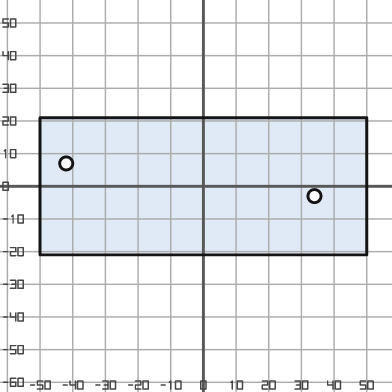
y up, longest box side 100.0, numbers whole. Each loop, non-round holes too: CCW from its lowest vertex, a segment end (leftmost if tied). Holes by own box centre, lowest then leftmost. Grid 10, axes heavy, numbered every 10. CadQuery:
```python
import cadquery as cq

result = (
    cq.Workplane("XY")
    .moveTo(-50.0, -21.0)
    .lineTo(50.0, -21.0)
    .lineTo(50.0, 21.0)
    .lineTo(-50.0, 21.0)
    .close()
    .moveTo(34.0, -3.0)
    .circle(2.0)
    .moveTo(-42.0, 7.0)
    .circle(2.0)
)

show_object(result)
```